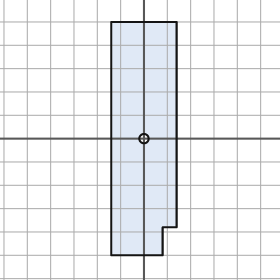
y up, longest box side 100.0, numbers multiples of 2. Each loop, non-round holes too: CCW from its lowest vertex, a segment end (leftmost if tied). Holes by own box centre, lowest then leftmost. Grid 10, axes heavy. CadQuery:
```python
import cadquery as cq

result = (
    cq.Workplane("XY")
    .moveTo(-14.0, -50.0)
    .lineTo(8.0, -50.0)
    .lineTo(8.0, -38.0)
    .lineTo(14.0, -38.0)
    .lineTo(14.0, 50.0)
    .lineTo(-14.0, 50.0)
    .close()
    .moveTo(0.0, 0.0)
    .circle(2.0)
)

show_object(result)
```